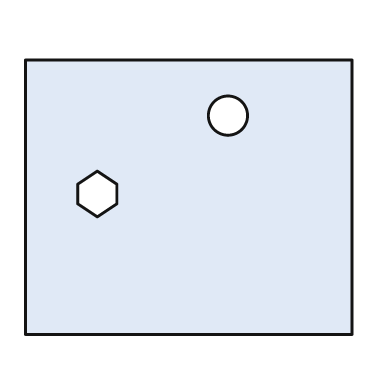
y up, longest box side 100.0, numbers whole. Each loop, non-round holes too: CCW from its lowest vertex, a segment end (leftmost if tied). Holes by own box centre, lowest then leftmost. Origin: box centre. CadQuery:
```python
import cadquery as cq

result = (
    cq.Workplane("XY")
    .moveTo(-50.0, -42.0)
    .lineTo(50.0, -42.0)
    .lineTo(50.0, 42.0)
    .lineTo(-50.0, 42.0)
    .close()
    .moveTo(-28.0, -6.0)
    .lineTo(-22.0, -2.0)
    .lineTo(-22.0, 4.0)
    .lineTo(-28.0, 8.0)
    .lineTo(-34.0, 4.0)
    .lineTo(-34.0, -2.0)
    .close()
    .moveTo(12.0, 25.0)
    .circle(6.0)
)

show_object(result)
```